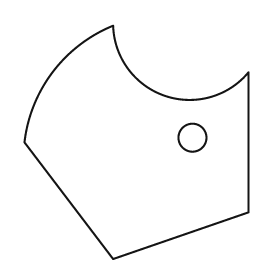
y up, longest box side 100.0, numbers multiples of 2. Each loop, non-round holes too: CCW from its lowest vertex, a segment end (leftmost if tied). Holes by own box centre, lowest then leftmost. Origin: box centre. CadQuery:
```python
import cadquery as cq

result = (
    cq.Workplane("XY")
    .moveTo(-10.0, -50.0)
    .lineTo(48.0, -30.0)
    .lineTo(48.0, 30.0)
    .threePointArc((12.0, 20.0), (-10.0, 50.0))
    .threePointArc((-36.0, 30.0), (-48.0, 0.0))
    .close()
    .moveTo(24.0, 2.0)
    .circle(6.0)
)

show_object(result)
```